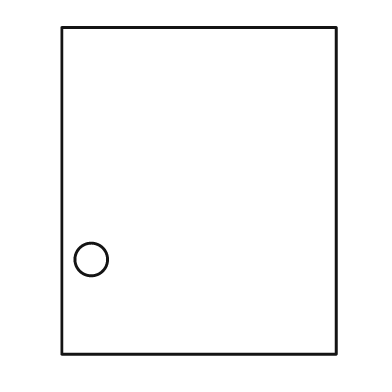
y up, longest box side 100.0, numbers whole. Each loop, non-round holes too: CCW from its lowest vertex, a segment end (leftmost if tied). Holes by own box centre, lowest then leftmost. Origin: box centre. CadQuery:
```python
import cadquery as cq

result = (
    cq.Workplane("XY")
    .moveTo(-42.0, -50.0)
    .lineTo(42.0, -50.0)
    .lineTo(42.0, 50.0)
    .lineTo(-42.0, 50.0)
    .close()
    .moveTo(-33.0, -21.0)
    .circle(5.0)
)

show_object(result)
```